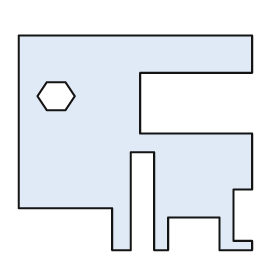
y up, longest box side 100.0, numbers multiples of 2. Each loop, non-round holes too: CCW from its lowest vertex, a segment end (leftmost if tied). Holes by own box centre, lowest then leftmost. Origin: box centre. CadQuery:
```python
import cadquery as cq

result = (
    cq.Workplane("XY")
    .moveTo(-10.0, -46.0)
    .lineTo(-2.0, -46.0)
    .lineTo(-2.0, -4.0)
    .lineTo(8.0, -4.0)
    .lineTo(8.0, -46.0)
    .lineTo(14.0, -46.0)
    .lineTo(14.0, -32.0)
    .lineTo(36.0, -32.0)
    .lineTo(36.0, -46.0)
    .lineTo(50.0, -46.0)
    .lineTo(50.0, -42.0)
    .lineTo(42.0, -42.0)
    .lineTo(42.0, -20.0)
    .lineTo(50.0, -20.0)
    .lineTo(50.0, 4.0)
    .lineTo(2.0, 4.0)
    .lineTo(2.0, 30.0)
    .lineTo(50.0, 30.0)
    .lineTo(50.0, 46.0)
    .lineTo(-50.0, 46.0)
    .lineTo(-50.0, -28.0)
    .lineTo(-10.0, -28.0)
    .close()
    .moveTo(-38.0, 14.0)
    .lineTo(-30.0, 14.0)
    .lineTo(-26.0, 20.0)
    .lineTo(-30.0, 26.0)
    .lineTo(-38.0, 26.0)
    .lineTo(-42.0, 20.0)
    .close()
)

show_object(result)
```